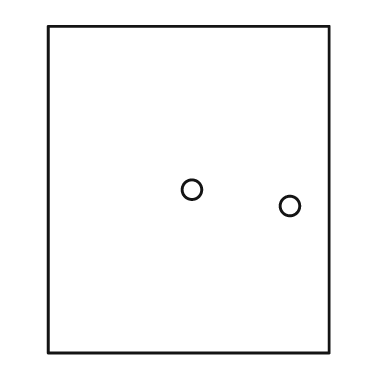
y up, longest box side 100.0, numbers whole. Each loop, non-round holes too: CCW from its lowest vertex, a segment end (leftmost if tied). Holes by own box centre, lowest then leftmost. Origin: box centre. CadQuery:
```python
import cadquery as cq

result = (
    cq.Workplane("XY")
    .moveTo(-43.0, -50.0)
    .lineTo(43.0, -50.0)
    .lineTo(43.0, 50.0)
    .lineTo(-43.0, 50.0)
    .close()
    .moveTo(31.0, -5.0)
    .circle(3.0)
    .moveTo(1.0, 0.0)
    .circle(3.0)
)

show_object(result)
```